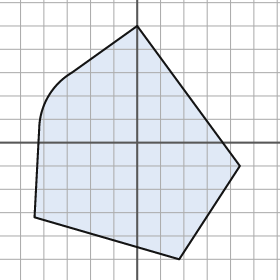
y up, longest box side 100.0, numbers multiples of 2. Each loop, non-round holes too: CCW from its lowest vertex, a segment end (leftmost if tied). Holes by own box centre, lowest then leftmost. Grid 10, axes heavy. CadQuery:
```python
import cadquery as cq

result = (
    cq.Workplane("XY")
    .moveTo(18.0, -50.0)
    .lineTo(44.0, -10.0)
    .lineTo(0.0, 50.0)
    .lineTo(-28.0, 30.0)
    .threePointArc((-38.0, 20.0), (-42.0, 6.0))
    .lineTo(-44.0, -32.0)
    .close()
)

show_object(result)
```